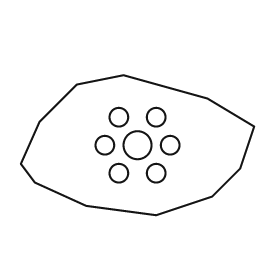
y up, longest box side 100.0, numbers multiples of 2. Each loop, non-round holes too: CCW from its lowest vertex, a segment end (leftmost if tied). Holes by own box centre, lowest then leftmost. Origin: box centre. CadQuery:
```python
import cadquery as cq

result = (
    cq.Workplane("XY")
    .moveTo(8.0, -30.0)
    .lineTo(32.0, -22.0)
    .lineTo(44.0, -10.0)
    .lineTo(50.0, 8.0)
    .lineTo(30.0, 20.0)
    .lineTo(-6.0, 30.0)
    .lineTo(-26.0, 26.0)
    .lineTo(-42.0, 10.0)
    .lineTo(-50.0, -8.0)
    .lineTo(-44.0, -16.0)
    .lineTo(-22.0, -26.0)
    .close()
    .moveTo(-8.0, -12.0)
    .circle(4.0)
    .moveTo(8.0, -12.0)
    .circle(4.0)
    .moveTo(-14.0, 0.0)
    .circle(4.0)
    .moveTo(0.0, 0.0)
    .circle(6.0)
    .moveTo(14.0, 0.0)
    .circle(4.0)
    .moveTo(-8.0, 12.0)
    .circle(4.0)
    .moveTo(8.0, 12.0)
    .circle(4.0)
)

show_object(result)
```